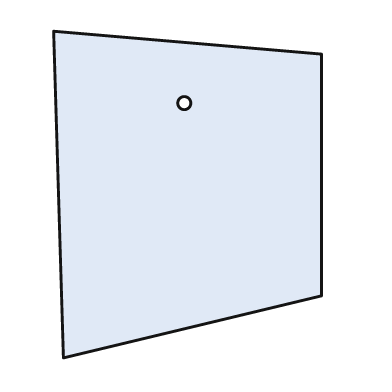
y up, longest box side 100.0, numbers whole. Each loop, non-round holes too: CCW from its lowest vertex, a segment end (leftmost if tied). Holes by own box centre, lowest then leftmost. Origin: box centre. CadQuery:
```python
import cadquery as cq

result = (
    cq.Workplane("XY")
    .moveTo(-38.0, -50.0)
    .lineTo(41.0, -31.0)
    .lineTo(41.0, 43.0)
    .lineTo(-41.0, 50.0)
    .close()
    .moveTo(-1.0, 28.0)
    .circle(2.0)
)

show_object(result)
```